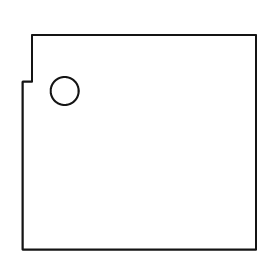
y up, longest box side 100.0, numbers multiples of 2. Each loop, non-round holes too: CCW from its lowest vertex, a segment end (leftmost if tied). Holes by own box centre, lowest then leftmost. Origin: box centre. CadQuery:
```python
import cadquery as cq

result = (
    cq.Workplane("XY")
    .moveTo(-50.0, -46.0)
    .lineTo(50.0, -46.0)
    .lineTo(50.0, 46.0)
    .lineTo(-46.0, 46.0)
    .lineTo(-46.0, 26.0)
    .lineTo(-50.0, 26.0)
    .close()
    .moveTo(-32.0, 22.0)
    .circle(6.0)
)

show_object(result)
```